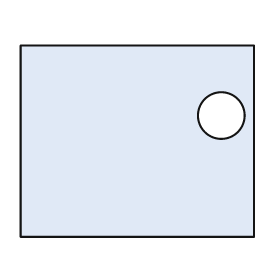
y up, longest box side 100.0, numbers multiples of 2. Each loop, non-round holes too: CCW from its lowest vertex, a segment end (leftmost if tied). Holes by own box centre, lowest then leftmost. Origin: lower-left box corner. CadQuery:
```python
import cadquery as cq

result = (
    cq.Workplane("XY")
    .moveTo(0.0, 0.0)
    .lineTo(100.0, 0.0)
    .lineTo(100.0, 82.0)
    .lineTo(0.0, 82.0)
    .close()
    .moveTo(86.0, 52.0)
    .circle(10.0)
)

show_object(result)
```